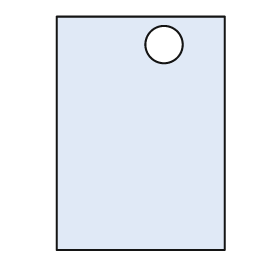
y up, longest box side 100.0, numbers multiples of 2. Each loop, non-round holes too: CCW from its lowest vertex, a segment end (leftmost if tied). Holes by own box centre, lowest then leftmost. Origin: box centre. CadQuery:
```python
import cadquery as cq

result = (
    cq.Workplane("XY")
    .moveTo(-36.0, -50.0)
    .lineTo(36.0, -50.0)
    .lineTo(36.0, 50.0)
    .lineTo(-36.0, 50.0)
    .close()
    .moveTo(10.0, 38.0)
    .circle(8.0)
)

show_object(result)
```